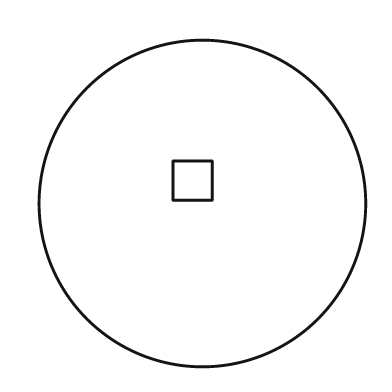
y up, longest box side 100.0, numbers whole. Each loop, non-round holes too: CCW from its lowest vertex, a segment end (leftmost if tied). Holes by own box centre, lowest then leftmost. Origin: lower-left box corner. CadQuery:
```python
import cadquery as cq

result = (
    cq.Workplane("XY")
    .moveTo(50.0, 50.0)
    .circle(50.0)
    .moveTo(41.0, 51.0)
    .lineTo(53.0, 51.0)
    .lineTo(53.0, 63.0)
    .lineTo(41.0, 63.0)
    .close()
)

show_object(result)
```